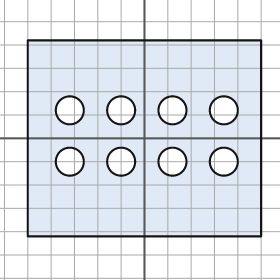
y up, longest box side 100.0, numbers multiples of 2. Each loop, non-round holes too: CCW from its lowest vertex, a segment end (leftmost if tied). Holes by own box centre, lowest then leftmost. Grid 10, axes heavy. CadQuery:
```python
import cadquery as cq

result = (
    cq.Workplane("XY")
    .moveTo(-50.0, -42.0)
    .lineTo(50.0, -42.0)
    .lineTo(50.0, 42.0)
    .lineTo(-50.0, 42.0)
    .close()
    .moveTo(-32.0, -10.0)
    .circle(6.0)
    .moveTo(-10.0, -10.0)
    .circle(6.0)
    .moveTo(12.0, -10.0)
    .circle(6.0)
    .moveTo(34.0, -10.0)
    .circle(6.0)
    .moveTo(-32.0, 12.0)
    .circle(6.0)
    .moveTo(-10.0, 12.0)
    .circle(6.0)
    .moveTo(12.0, 12.0)
    .circle(6.0)
    .moveTo(34.0, 12.0)
    .circle(6.0)
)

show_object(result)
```